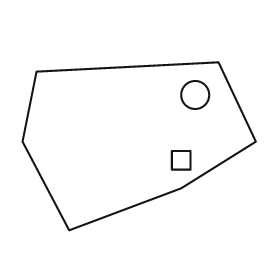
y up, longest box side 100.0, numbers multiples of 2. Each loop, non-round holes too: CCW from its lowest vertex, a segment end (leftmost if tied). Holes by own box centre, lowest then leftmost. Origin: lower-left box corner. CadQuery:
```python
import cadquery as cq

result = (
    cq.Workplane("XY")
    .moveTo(20.0, 0.0)
    .lineTo(68.0, 18.0)
    .lineTo(100.0, 38.0)
    .lineTo(84.0, 72.0)
    .lineTo(6.0, 68.0)
    .lineTo(0.0, 38.0)
    .close()
    .moveTo(64.0, 26.0)
    .lineTo(72.0, 26.0)
    .lineTo(72.0, 34.0)
    .lineTo(64.0, 34.0)
    .close()
    .moveTo(74.0, 58.0)
    .circle(6.0)
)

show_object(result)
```